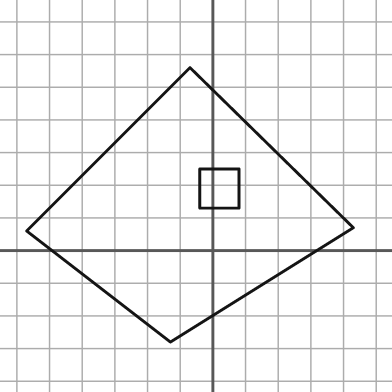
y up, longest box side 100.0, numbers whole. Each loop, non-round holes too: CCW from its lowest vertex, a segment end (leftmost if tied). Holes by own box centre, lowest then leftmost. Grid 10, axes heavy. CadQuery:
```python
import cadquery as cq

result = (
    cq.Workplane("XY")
    .moveTo(-13.0, -28.0)
    .lineTo(43.0, 7.0)
    .lineTo(-7.0, 56.0)
    .lineTo(-57.0, 6.0)
    .close()
    .moveTo(-4.0, 13.0)
    .lineTo(8.0, 13.0)
    .lineTo(8.0, 25.0)
    .lineTo(-4.0, 25.0)
    .close()
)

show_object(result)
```